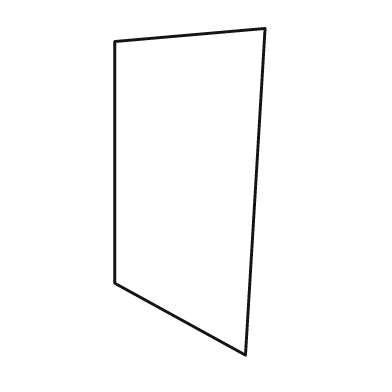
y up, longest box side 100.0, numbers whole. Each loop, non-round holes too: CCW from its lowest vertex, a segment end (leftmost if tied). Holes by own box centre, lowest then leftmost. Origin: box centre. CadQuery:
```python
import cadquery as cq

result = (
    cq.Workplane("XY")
    .moveTo(17.0, -50.0)
    .lineTo(23.0, 50.0)
    .lineTo(-23.0, 46.0)
    .lineTo(-23.0, -28.0)
    .close()
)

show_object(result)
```